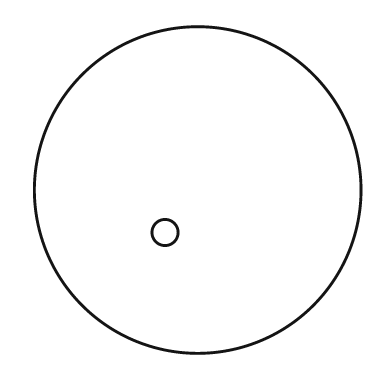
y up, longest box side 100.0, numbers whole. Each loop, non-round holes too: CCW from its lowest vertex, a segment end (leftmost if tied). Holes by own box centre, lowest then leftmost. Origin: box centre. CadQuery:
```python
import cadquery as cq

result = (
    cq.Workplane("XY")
    .moveTo(0.0, 0.0)
    .circle(50.0)
    .moveTo(-10.0, -13.0)
    .circle(4.0)
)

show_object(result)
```